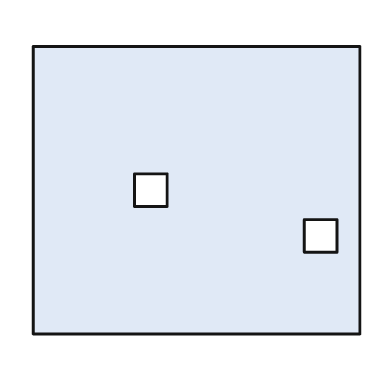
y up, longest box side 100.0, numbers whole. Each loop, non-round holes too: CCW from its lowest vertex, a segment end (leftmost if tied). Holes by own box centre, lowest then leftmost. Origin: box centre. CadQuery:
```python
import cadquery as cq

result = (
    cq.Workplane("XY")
    .moveTo(-50.0, -44.0)
    .lineTo(50.0, -44.0)
    .lineTo(50.0, 44.0)
    .lineTo(-50.0, 44.0)
    .close()
    .moveTo(33.0, -19.0)
    .lineTo(43.0, -19.0)
    .lineTo(43.0, -9.0)
    .lineTo(33.0, -9.0)
    .close()
    .moveTo(-19.0, -5.0)
    .lineTo(-9.0, -5.0)
    .lineTo(-9.0, 5.0)
    .lineTo(-19.0, 5.0)
    .close()
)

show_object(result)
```